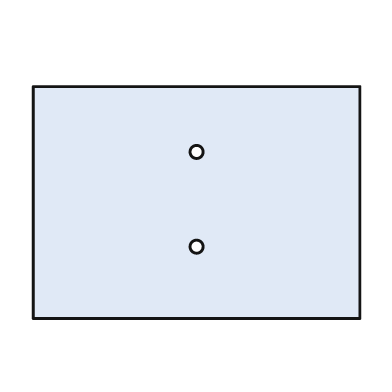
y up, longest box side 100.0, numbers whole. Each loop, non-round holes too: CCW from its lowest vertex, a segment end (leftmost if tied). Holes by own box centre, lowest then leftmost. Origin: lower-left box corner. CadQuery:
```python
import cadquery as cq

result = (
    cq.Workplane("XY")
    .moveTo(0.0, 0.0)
    .lineTo(100.0, 0.0)
    .lineTo(100.0, 71.0)
    .lineTo(0.0, 71.0)
    .close()
    .moveTo(50.0, 22.0)
    .circle(2.0)
    .moveTo(50.0, 51.0)
    .circle(2.0)
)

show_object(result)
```